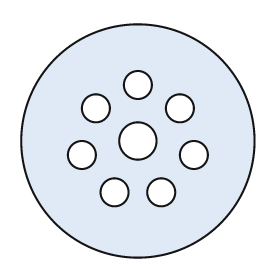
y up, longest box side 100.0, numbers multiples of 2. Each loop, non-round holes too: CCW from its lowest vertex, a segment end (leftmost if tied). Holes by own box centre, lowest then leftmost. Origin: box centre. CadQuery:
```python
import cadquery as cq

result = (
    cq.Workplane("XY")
    .moveTo(0.0, 0.0)
    .circle(50.0)
    .moveTo(-10.0, -22.0)
    .circle(6.0)
    .moveTo(10.0, -22.0)
    .circle(6.0)
    .moveTo(-24.0, -6.0)
    .circle(6.0)
    .moveTo(24.0, -6.0)
    .circle(6.0)
    .moveTo(0.0, 0.0)
    .circle(8.0)
    .moveTo(-18.0, 14.0)
    .circle(6.0)
    .moveTo(18.0, 14.0)
    .circle(6.0)
    .moveTo(0.0, 24.0)
    .circle(6.0)
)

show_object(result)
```